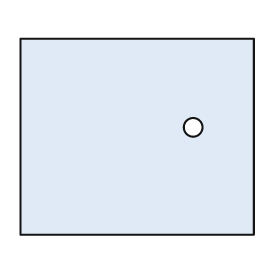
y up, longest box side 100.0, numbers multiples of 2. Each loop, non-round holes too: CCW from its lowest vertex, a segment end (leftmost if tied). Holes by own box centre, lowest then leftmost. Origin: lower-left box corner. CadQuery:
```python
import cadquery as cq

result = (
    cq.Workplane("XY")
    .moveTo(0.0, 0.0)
    .lineTo(100.0, 0.0)
    .lineTo(100.0, 84.0)
    .lineTo(0.0, 84.0)
    .close()
    .moveTo(74.0, 46.0)
    .circle(4.0)
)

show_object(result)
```